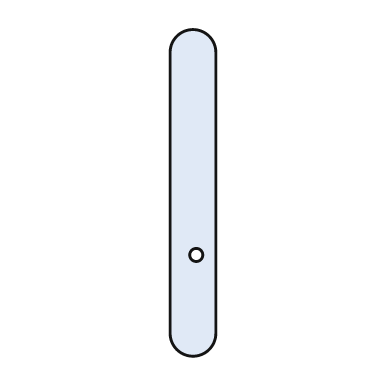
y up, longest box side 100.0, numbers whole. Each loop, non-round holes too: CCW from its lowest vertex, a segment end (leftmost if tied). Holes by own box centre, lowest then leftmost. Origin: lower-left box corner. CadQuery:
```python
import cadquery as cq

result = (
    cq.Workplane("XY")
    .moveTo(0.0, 7.0)
    .threePointArc((7.0, 0.0), (14.0, 7.0))
    .lineTo(14.0, 93.0)
    .threePointArc((7.0, 100.0), (0.0, 93.0))
    .close()
    .moveTo(8.0, 31.0)
    .circle(2.0)
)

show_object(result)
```